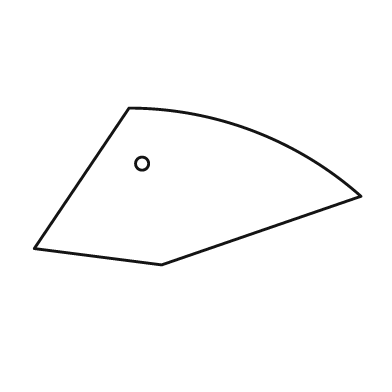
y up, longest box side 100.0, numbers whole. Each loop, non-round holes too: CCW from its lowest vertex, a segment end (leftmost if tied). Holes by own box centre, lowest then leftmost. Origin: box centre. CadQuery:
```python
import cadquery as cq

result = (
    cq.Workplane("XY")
    .moveTo(-11.0, -24.0)
    .lineTo(50.0, -3.0)
    .threePointArc((17.0, 17.0), (-21.0, 24.0))
    .lineTo(-50.0, -19.0)
    .close()
    .moveTo(-17.0, 7.0)
    .circle(2.0)
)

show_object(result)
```